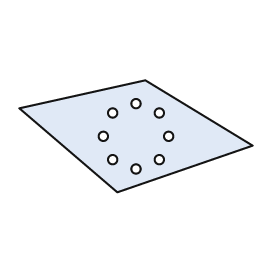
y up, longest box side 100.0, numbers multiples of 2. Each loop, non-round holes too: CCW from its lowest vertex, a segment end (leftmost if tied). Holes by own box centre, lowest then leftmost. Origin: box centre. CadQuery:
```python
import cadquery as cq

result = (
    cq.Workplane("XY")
    .moveTo(-8.0, -24.0)
    .lineTo(50.0, -4.0)
    .lineTo(4.0, 24.0)
    .lineTo(-50.0, 12.0)
    .close()
    .moveTo(0.0, -14.0)
    .circle(2.0)
    .moveTo(-10.0, -10.0)
    .circle(2.0)
    .moveTo(10.0, -10.0)
    .circle(2.0)
    .moveTo(-14.0, 0.0)
    .circle(2.0)
    .moveTo(14.0, 0.0)
    .circle(2.0)
    .moveTo(-10.0, 10.0)
    .circle(2.0)
    .moveTo(10.0, 10.0)
    .circle(2.0)
    .moveTo(0.0, 14.0)
    .circle(2.0)
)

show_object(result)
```